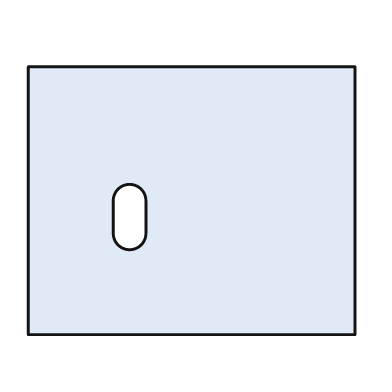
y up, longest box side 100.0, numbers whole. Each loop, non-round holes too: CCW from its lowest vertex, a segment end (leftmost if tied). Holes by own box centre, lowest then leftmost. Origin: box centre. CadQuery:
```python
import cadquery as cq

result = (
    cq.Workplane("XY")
    .moveTo(-50.0, -41.0)
    .lineTo(50.0, -41.0)
    .lineTo(50.0, 41.0)
    .lineTo(-50.0, 41.0)
    .close()
    .moveTo(-24.0, -10.0)
    .threePointArc((-19.0, -15.0), (-14.0, -10.0))
    .lineTo(-14.0, 0.0)
    .threePointArc((-19.0, 5.0), (-24.0, 0.0))
    .close()
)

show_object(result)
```